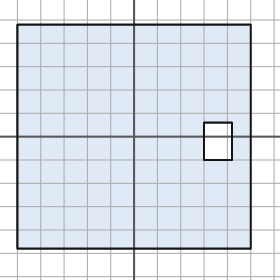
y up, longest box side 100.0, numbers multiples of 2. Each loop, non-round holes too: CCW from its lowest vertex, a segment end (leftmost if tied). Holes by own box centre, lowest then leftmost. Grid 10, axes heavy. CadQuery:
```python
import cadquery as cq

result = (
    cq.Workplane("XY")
    .moveTo(-50.0, -48.0)
    .lineTo(50.0, -48.0)
    .lineTo(50.0, 48.0)
    .lineTo(-50.0, 48.0)
    .close()
    .moveTo(30.0, -10.0)
    .lineTo(42.0, -10.0)
    .lineTo(42.0, 6.0)
    .lineTo(30.0, 6.0)
    .close()
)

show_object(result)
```